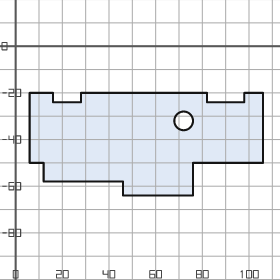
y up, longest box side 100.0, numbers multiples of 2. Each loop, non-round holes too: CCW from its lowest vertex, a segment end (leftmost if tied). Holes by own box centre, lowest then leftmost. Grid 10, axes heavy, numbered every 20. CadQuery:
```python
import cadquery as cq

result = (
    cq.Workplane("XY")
    .moveTo(46.0, -64.0)
    .lineTo(76.0, -64.0)
    .lineTo(76.0, -50.0)
    .lineTo(106.0, -50.0)
    .lineTo(106.0, -20.0)
    .lineTo(98.0, -20.0)
    .lineTo(98.0, -24.0)
    .lineTo(82.0, -24.0)
    .lineTo(82.0, -20.0)
    .lineTo(28.0, -20.0)
    .lineTo(28.0, -24.0)
    .lineTo(16.0, -24.0)
    .lineTo(16.0, -20.0)
    .lineTo(6.0, -20.0)
    .lineTo(6.0, -50.0)
    .lineTo(12.0, -50.0)
    .lineTo(12.0, -58.0)
    .lineTo(46.0, -58.0)
    .close()
    .moveTo(72.0, -32.0)
    .circle(4.0)
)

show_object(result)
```